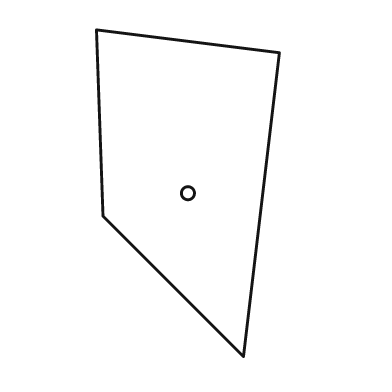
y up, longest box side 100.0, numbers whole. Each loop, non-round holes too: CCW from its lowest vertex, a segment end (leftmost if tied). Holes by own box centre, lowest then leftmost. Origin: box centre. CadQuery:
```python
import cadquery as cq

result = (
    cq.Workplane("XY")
    .moveTo(17.0, -50.0)
    .lineTo(28.0, 43.0)
    .lineTo(-28.0, 50.0)
    .lineTo(-26.0, -7.0)
    .close()
    .moveTo(0.0, 0.0)
    .circle(2.0)
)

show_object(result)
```